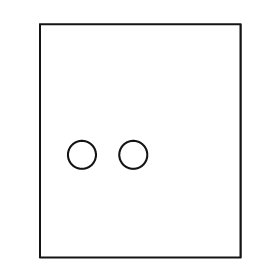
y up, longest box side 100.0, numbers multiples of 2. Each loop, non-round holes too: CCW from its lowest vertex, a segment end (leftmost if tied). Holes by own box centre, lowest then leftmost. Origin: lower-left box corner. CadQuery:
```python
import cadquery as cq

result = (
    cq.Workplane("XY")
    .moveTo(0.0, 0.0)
    .lineTo(86.0, 0.0)
    .lineTo(86.0, 100.0)
    .lineTo(0.0, 100.0)
    .close()
    .moveTo(18.0, 44.0)
    .circle(6.0)
    .moveTo(40.0, 44.0)
    .circle(6.0)
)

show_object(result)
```